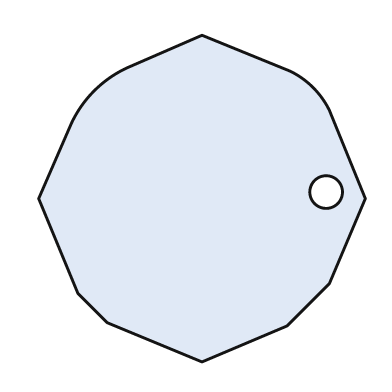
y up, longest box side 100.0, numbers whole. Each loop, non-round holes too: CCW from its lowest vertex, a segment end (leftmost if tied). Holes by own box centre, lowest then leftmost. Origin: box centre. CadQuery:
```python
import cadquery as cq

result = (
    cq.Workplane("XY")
    .moveTo(0.0, -50.0)
    .lineTo(26.0, -39.0)
    .lineTo(39.0, -26.0)
    .lineTo(50.0, 0.0)
    .lineTo(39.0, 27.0)
    .threePointArc((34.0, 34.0), (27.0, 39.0))
    .lineTo(0.0, 50.0)
    .lineTo(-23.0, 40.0)
    .threePointArc((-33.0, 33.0), (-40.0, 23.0))
    .lineTo(-50.0, 0.0)
    .lineTo(-38.0, -29.0)
    .lineTo(-29.0, -38.0)
    .close()
    .moveTo(38.0, 2.0)
    .circle(5.0)
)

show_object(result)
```